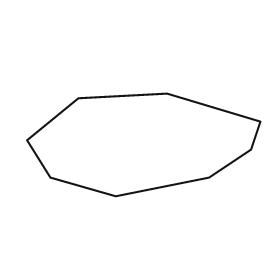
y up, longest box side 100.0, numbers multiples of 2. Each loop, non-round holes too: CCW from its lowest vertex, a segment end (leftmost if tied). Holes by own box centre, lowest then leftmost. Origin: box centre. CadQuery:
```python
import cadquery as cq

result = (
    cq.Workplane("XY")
    .moveTo(-12.0, -22.0)
    .lineTo(28.0, -14.0)
    .lineTo(46.0, -2.0)
    .lineTo(50.0, 10.0)
    .lineTo(10.0, 22.0)
    .lineTo(-28.0, 20.0)
    .lineTo(-50.0, 2.0)
    .lineTo(-40.0, -14.0)
    .close()
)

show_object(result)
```